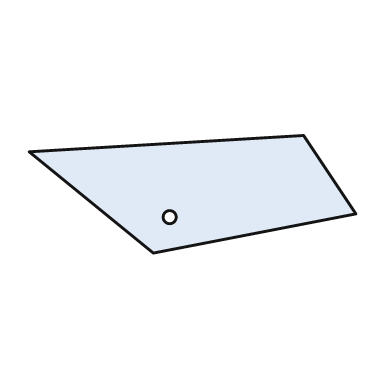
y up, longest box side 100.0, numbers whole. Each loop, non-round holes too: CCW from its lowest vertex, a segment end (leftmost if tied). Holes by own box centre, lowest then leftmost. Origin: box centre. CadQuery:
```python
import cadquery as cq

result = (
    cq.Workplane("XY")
    .moveTo(-12.0, -18.0)
    .lineTo(50.0, -6.0)
    .lineTo(34.0, 18.0)
    .lineTo(-50.0, 13.0)
    .close()
    .moveTo(-7.0, -7.0)
    .circle(2.0)
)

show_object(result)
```